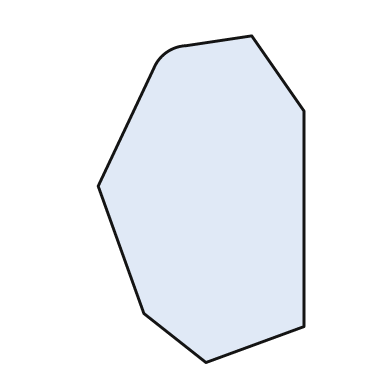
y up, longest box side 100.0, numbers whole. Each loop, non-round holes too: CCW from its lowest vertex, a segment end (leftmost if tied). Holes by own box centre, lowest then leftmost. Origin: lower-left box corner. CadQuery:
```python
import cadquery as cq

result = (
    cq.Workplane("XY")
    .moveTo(33.0, 0.0)
    .lineTo(63.0, 11.0)
    .lineTo(63.0, 77.0)
    .lineTo(47.0, 100.0)
    .lineTo(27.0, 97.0)
    .threePointArc((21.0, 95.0), (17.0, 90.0))
    .lineTo(0.0, 54.0)
    .lineTo(14.0, 15.0)
    .close()
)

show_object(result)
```